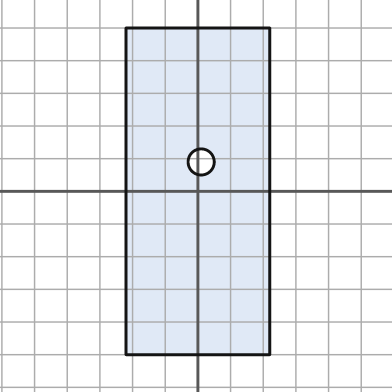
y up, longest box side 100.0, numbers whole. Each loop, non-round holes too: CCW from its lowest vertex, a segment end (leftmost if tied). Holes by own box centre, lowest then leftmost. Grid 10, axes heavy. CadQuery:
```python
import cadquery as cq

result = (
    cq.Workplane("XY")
    .moveTo(-22.0, -50.0)
    .lineTo(22.0, -50.0)
    .lineTo(22.0, 50.0)
    .lineTo(-22.0, 50.0)
    .close()
    .moveTo(1.0, 9.0)
    .circle(4.0)
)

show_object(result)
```